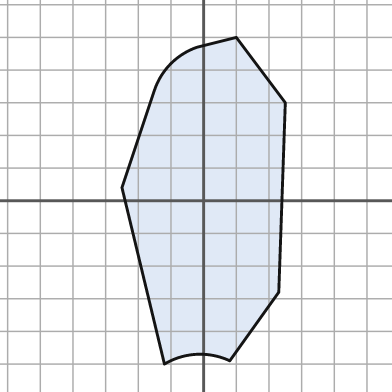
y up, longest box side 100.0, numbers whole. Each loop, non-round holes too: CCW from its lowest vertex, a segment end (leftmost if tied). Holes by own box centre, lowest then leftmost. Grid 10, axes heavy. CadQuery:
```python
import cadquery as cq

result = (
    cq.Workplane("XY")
    .moveTo(-12.0, -50.0)
    .threePointArc((-2.0, -47.0), (8.0, -49.0))
    .lineTo(23.0, -28.0)
    .lineTo(25.0, 30.0)
    .lineTo(10.0, 50.0)
    .lineTo(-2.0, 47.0)
    .threePointArc((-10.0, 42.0), (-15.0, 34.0))
    .lineTo(-25.0, 4.0)
    .close()
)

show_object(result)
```